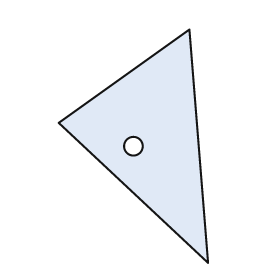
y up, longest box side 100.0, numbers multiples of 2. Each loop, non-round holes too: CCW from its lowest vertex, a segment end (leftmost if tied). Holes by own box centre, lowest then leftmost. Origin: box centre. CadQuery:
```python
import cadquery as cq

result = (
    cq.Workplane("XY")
    .moveTo(32.0, -50.0)
    .lineTo(24.0, 50.0)
    .lineTo(-32.0, 10.0)
    .close()
    .moveTo(0.0, 0.0)
    .circle(4.0)
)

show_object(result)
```